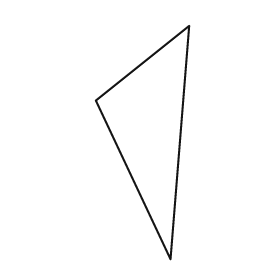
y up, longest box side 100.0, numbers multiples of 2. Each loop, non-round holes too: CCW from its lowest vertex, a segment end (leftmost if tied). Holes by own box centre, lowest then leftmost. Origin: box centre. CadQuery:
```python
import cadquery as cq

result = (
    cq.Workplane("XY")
    .moveTo(12.0, -50.0)
    .lineTo(20.0, 50.0)
    .lineTo(-20.0, 18.0)
    .close()
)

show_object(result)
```